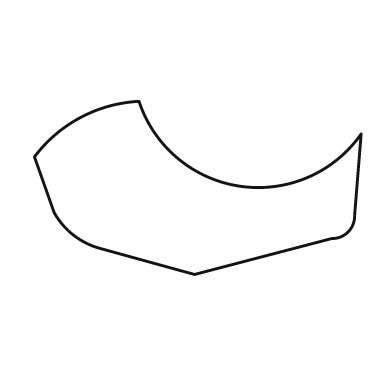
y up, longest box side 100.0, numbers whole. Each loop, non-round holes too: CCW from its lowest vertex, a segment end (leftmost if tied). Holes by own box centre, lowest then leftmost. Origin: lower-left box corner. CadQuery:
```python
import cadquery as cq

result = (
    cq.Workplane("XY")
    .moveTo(49.0, 0.0)
    .lineTo(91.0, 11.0)
    .threePointArc((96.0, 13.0), (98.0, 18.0))
    .lineTo(100.0, 43.0)
    .threePointArc((63.0, 27.0), (32.0, 53.0))
    .threePointArc((14.0, 48.0), (0.0, 36.0))
    .lineTo(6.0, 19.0)
    .threePointArc((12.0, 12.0), (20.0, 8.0))
    .close()
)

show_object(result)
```